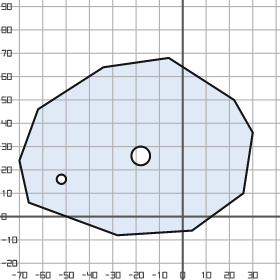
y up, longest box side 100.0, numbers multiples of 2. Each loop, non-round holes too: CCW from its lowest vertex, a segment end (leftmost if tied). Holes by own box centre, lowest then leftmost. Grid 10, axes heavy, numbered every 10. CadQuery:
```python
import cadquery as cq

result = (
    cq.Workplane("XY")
    .moveTo(-28.0, -8.0)
    .lineTo(4.0, -6.0)
    .lineTo(26.0, 10.0)
    .lineTo(30.0, 36.0)
    .lineTo(22.0, 50.0)
    .lineTo(-6.0, 68.0)
    .lineTo(-34.0, 64.0)
    .lineTo(-62.0, 46.0)
    .lineTo(-70.0, 24.0)
    .lineTo(-66.0, 6.0)
    .close()
    .moveTo(-52.0, 16.0)
    .circle(2.0)
    .moveTo(-18.0, 26.0)
    .circle(4.0)
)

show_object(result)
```